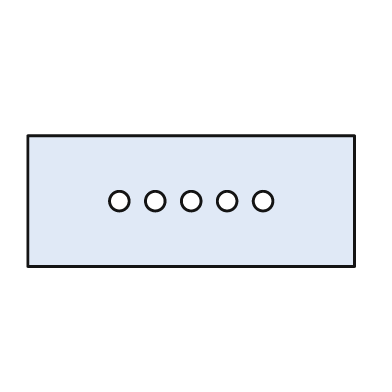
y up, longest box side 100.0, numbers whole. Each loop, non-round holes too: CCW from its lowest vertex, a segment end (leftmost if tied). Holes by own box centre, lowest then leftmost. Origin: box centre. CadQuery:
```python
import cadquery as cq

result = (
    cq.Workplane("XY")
    .moveTo(-50.0, -20.0)
    .lineTo(50.0, -20.0)
    .lineTo(50.0, 20.0)
    .lineTo(-50.0, 20.0)
    .close()
    .moveTo(-22.0, 0.0)
    .circle(3.0)
    .moveTo(-11.0, 0.0)
    .circle(3.0)
    .moveTo(0.0, 0.0)
    .circle(3.0)
    .moveTo(11.0, 0.0)
    .circle(3.0)
    .moveTo(22.0, 0.0)
    .circle(3.0)
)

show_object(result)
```